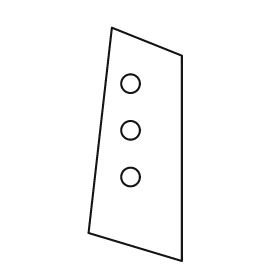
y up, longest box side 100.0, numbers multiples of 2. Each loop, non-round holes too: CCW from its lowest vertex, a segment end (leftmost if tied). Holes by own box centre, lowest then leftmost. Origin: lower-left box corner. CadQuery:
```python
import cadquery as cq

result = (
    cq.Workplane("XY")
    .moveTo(40.0, 0.0)
    .lineTo(40.0, 88.0)
    .lineTo(10.0, 100.0)
    .lineTo(0.0, 12.0)
    .close()
    .moveTo(18.0, 36.0)
    .circle(4.0)
    .moveTo(18.0, 56.0)
    .circle(4.0)
    .moveTo(18.0, 76.0)
    .circle(4.0)
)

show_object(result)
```